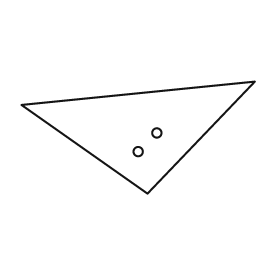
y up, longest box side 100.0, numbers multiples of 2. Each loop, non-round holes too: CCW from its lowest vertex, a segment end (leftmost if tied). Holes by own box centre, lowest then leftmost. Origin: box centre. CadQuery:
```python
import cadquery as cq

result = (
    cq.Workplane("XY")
    .moveTo(4.0, -24.0)
    .lineTo(50.0, 24.0)
    .lineTo(-50.0, 14.0)
    .close()
    .moveTo(0.0, -6.0)
    .circle(2.0)
    .moveTo(8.0, 2.0)
    .circle(2.0)
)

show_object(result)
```